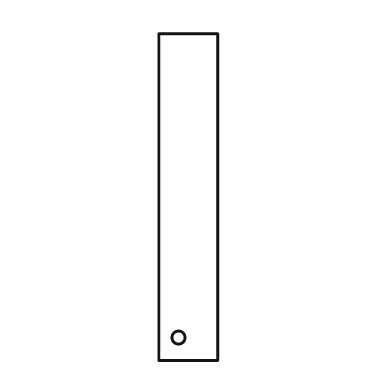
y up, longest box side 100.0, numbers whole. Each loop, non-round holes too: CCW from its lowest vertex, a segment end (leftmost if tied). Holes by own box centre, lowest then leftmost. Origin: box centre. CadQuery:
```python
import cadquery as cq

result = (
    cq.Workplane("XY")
    .moveTo(-9.0, -50.0)
    .lineTo(9.0, -50.0)
    .lineTo(9.0, 50.0)
    .lineTo(-9.0, 50.0)
    .close()
    .moveTo(-3.0, -43.0)
    .circle(2.0)
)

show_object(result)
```